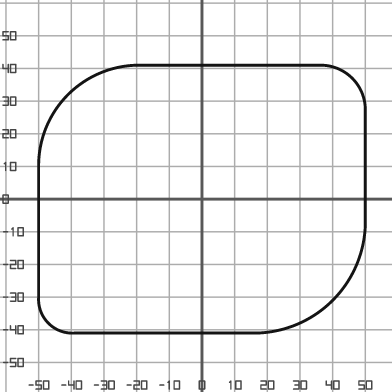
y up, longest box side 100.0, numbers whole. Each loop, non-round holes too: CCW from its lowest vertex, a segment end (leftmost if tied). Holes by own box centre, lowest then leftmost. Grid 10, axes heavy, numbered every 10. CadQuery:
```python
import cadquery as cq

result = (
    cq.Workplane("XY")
    .moveTo(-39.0, -41.0)
    .lineTo(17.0, -41.0)
    .threePointArc((40.0, -31.0), (50.0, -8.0))
    .lineTo(50.0, 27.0)
    .threePointArc((46.0, 37.0), (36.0, 41.0))
    .lineTo(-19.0, 41.0)
    .threePointArc((-41.0, 32.0), (-50.0, 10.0))
    .lineTo(-50.0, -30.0)
    .threePointArc((-47.0, -38.0), (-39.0, -41.0))
    .close()
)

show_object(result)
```